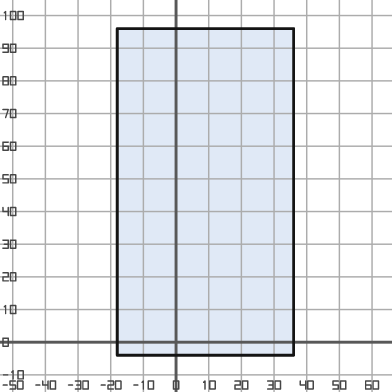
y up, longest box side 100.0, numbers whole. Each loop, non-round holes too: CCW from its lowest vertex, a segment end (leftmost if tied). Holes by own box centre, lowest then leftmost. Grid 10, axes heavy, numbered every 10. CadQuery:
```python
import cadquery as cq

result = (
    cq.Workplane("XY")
    .moveTo(-18.0, -4.0)
    .lineTo(36.0, -4.0)
    .lineTo(36.0, 96.0)
    .lineTo(-18.0, 96.0)
    .close()
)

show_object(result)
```